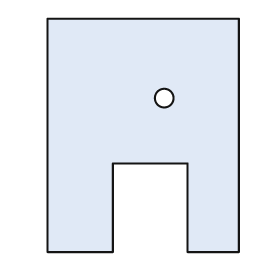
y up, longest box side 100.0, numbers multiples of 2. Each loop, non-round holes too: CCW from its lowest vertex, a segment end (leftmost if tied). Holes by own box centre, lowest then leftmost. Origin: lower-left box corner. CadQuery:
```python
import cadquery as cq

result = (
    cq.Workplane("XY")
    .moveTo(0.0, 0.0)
    .lineTo(28.0, 0.0)
    .lineTo(28.0, 38.0)
    .lineTo(60.0, 38.0)
    .lineTo(60.0, 0.0)
    .lineTo(82.0, 0.0)
    .lineTo(82.0, 100.0)
    .lineTo(0.0, 100.0)
    .close()
    .moveTo(50.0, 66.0)
    .circle(4.0)
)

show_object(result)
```